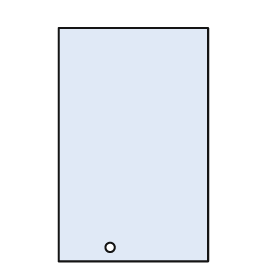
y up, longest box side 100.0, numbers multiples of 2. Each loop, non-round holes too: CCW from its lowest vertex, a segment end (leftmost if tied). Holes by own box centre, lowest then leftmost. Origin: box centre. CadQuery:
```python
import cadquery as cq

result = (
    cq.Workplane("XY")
    .moveTo(-32.0, -50.0)
    .lineTo(32.0, -50.0)
    .lineTo(32.0, 50.0)
    .lineTo(-32.0, 50.0)
    .close()
    .moveTo(-10.0, -44.0)
    .circle(2.0)
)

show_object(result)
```